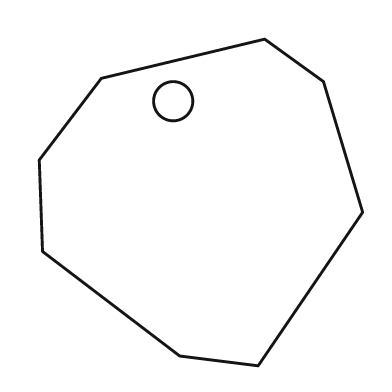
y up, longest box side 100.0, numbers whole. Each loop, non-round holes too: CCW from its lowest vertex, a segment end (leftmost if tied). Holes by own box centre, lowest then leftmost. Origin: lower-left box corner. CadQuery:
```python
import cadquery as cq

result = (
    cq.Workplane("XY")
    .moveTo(67.0, 0.0)
    .lineTo(99.0, 47.0)
    .lineTo(87.0, 87.0)
    .lineTo(69.0, 100.0)
    .lineTo(19.0, 88.0)
    .lineTo(0.0, 63.0)
    .lineTo(1.0, 35.0)
    .lineTo(43.0, 3.0)
    .close()
    .moveTo(41.0, 81.0)
    .circle(6.0)
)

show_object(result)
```